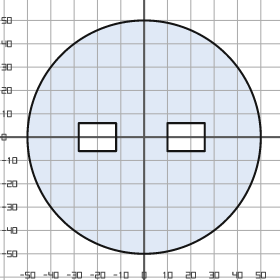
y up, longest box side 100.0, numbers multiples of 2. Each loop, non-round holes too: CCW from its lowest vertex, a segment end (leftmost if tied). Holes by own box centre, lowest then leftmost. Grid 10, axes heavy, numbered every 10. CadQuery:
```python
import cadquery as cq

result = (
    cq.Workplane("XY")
    .moveTo(0.0, 0.0)
    .circle(50.0)
    .moveTo(-28.0, -6.0)
    .lineTo(-12.0, -6.0)
    .lineTo(-12.0, 6.0)
    .lineTo(-28.0, 6.0)
    .close()
    .moveTo(10.0, -6.0)
    .lineTo(26.0, -6.0)
    .lineTo(26.0, 6.0)
    .lineTo(10.0, 6.0)
    .close()
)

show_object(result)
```